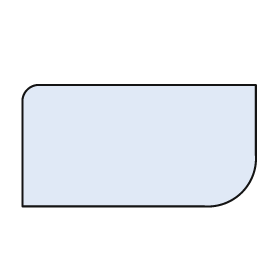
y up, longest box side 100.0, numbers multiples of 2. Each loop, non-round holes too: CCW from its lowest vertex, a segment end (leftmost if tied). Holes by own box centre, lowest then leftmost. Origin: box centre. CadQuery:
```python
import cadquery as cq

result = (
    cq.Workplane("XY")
    .moveTo(-50.0, -26.0)
    .lineTo(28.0, -26.0)
    .threePointArc((44.0, -20.0), (50.0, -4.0))
    .lineTo(50.0, 26.0)
    .lineTo(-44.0, 26.0)
    .threePointArc((-48.0, 24.0), (-50.0, 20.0))
    .close()
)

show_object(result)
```